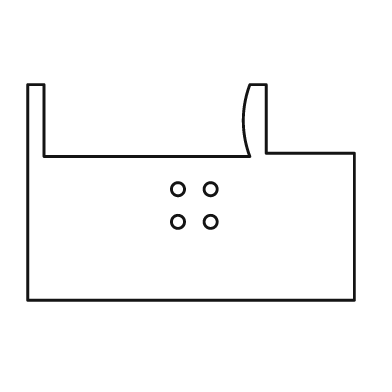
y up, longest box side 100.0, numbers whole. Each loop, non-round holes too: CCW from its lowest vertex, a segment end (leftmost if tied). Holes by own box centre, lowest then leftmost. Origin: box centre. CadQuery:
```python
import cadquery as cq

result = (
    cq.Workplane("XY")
    .moveTo(-50.0, -33.0)
    .lineTo(50.0, -33.0)
    .lineTo(50.0, 12.0)
    .lineTo(23.0, 12.0)
    .lineTo(23.0, 33.0)
    .lineTo(18.0, 33.0)
    .threePointArc((16.0, 22.0), (18.0, 11.0))
    .lineTo(-45.0, 11.0)
    .lineTo(-45.0, 33.0)
    .lineTo(-50.0, 33.0)
    .close()
    .moveTo(-4.0, -9.0)
    .circle(2.0)
    .moveTo(6.0, -9.0)
    .circle(2.0)
    .moveTo(-4.0, 1.0)
    .circle(2.0)
    .moveTo(6.0, 1.0)
    .circle(2.0)
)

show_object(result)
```